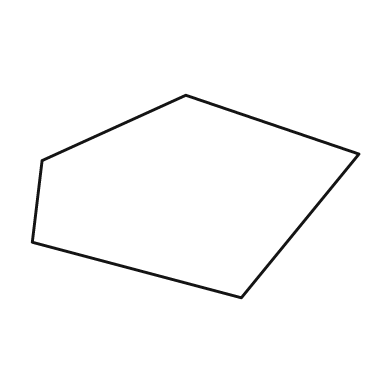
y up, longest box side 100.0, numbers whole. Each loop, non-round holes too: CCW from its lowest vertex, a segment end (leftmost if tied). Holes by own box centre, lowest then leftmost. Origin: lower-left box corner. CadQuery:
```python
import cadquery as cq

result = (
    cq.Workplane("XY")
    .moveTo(64.0, 0.0)
    .lineTo(100.0, 44.0)
    .lineTo(47.0, 62.0)
    .lineTo(3.0, 42.0)
    .lineTo(0.0, 17.0)
    .close()
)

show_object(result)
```